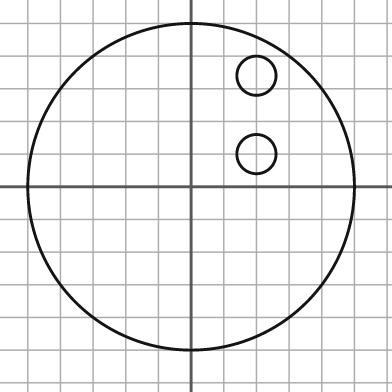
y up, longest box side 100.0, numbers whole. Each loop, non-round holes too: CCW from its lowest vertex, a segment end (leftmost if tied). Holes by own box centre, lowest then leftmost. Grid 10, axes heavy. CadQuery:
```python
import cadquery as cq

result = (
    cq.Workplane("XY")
    .moveTo(0.0, 0.0)
    .circle(50.0)
    .moveTo(20.0, 10.0)
    .circle(6.0)
    .moveTo(20.0, 34.0)
    .circle(6.0)
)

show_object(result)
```